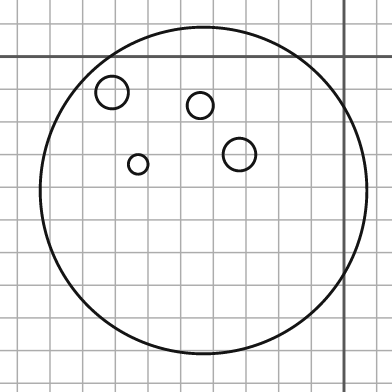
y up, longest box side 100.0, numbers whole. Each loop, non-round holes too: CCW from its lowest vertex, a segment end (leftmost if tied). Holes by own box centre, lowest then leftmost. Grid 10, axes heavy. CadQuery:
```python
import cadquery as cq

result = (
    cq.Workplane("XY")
    .moveTo(-43.0, -41.0)
    .circle(50.0)
    .moveTo(-63.0, -33.0)
    .circle(3.0)
    .moveTo(-32.0, -30.0)
    .circle(5.0)
    .moveTo(-44.0, -15.0)
    .circle(4.0)
    .moveTo(-71.0, -11.0)
    .circle(5.0)
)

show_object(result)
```